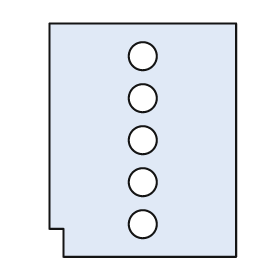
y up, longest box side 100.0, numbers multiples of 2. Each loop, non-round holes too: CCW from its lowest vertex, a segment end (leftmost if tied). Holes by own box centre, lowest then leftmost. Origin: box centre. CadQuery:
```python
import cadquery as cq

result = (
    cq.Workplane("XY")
    .moveTo(-34.0, -50.0)
    .lineTo(40.0, -50.0)
    .lineTo(40.0, 50.0)
    .lineTo(-40.0, 50.0)
    .lineTo(-40.0, -38.0)
    .lineTo(-34.0, -38.0)
    .close()
    .moveTo(0.0, -36.0)
    .circle(6.0)
    .moveTo(0.0, -18.0)
    .circle(6.0)
    .moveTo(0.0, 0.0)
    .circle(6.0)
    .moveTo(0.0, 18.0)
    .circle(6.0)
    .moveTo(0.0, 36.0)
    .circle(6.0)
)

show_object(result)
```